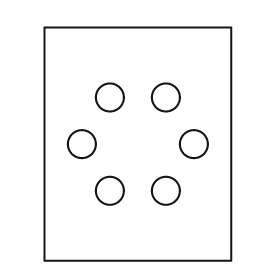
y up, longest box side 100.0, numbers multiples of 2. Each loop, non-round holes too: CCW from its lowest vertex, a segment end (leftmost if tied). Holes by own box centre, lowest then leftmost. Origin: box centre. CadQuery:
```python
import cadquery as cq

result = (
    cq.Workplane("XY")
    .moveTo(-40.0, -50.0)
    .lineTo(40.0, -50.0)
    .lineTo(40.0, 50.0)
    .lineTo(-40.0, 50.0)
    .close()
    .moveTo(-12.0, -20.0)
    .circle(6.0)
    .moveTo(12.0, -20.0)
    .circle(6.0)
    .moveTo(-24.0, 0.0)
    .circle(6.0)
    .moveTo(24.0, 0.0)
    .circle(6.0)
    .moveTo(-12.0, 20.0)
    .circle(6.0)
    .moveTo(12.0, 20.0)
    .circle(6.0)
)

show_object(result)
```